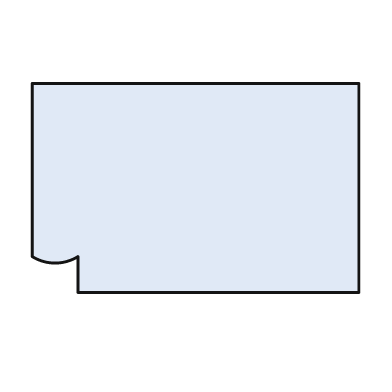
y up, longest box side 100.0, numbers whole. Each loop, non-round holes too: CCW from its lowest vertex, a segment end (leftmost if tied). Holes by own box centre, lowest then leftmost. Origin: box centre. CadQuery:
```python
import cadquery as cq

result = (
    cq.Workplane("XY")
    .moveTo(-36.0, -32.0)
    .lineTo(50.0, -32.0)
    .lineTo(50.0, 32.0)
    .lineTo(-50.0, 32.0)
    .lineTo(-50.0, -21.0)
    .threePointArc((-43.0, -23.0), (-36.0, -21.0))
    .close()
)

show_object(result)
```